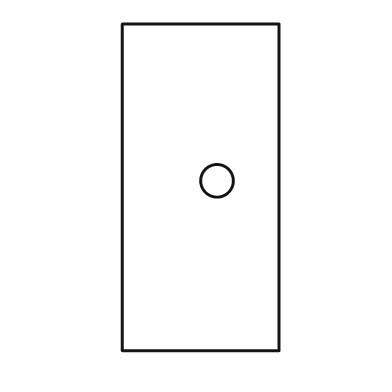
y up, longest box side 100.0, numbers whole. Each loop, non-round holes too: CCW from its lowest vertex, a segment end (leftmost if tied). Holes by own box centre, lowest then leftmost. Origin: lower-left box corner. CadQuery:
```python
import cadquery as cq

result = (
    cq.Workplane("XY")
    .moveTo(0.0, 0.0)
    .lineTo(48.0, 0.0)
    .lineTo(48.0, 100.0)
    .lineTo(0.0, 100.0)
    .close()
    .moveTo(29.0, 52.0)
    .circle(5.0)
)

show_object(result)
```